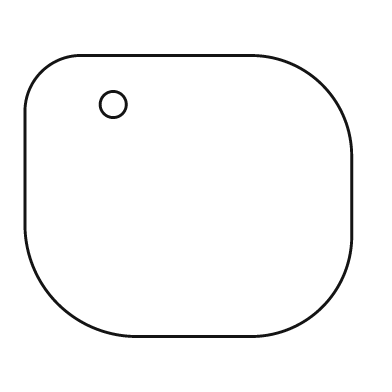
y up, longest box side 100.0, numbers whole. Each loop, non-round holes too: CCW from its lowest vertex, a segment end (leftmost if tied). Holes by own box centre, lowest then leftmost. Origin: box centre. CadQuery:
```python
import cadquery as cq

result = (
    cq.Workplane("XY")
    .moveTo(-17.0, -43.0)
    .lineTo(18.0, -43.0)
    .threePointArc((41.0, -34.0), (50.0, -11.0))
    .lineTo(50.0, 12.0)
    .threePointArc((41.0, 34.0), (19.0, 43.0))
    .lineTo(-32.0, 43.0)
    .threePointArc((-45.0, 38.0), (-50.0, 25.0))
    .lineTo(-50.0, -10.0)
    .threePointArc((-40.0, -33.0), (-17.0, -43.0))
    .close()
    .moveTo(-23.0, 28.0)
    .circle(4.0)
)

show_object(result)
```